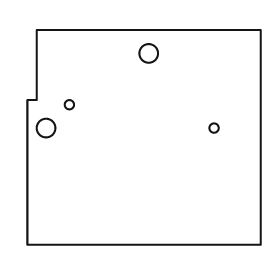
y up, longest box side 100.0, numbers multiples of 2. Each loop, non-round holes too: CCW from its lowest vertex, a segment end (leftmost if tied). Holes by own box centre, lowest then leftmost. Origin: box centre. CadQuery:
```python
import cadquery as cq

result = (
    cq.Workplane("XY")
    .moveTo(-50.0, -46.0)
    .lineTo(50.0, -46.0)
    .lineTo(50.0, 46.0)
    .lineTo(-46.0, 46.0)
    .lineTo(-46.0, 16.0)
    .lineTo(-50.0, 16.0)
    .close()
    .moveTo(-42.0, 4.0)
    .circle(4.0)
    .moveTo(30.0, 4.0)
    .circle(2.0)
    .moveTo(-32.0, 14.0)
    .circle(2.0)
    .moveTo(2.0, 36.0)
    .circle(4.0)
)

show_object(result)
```